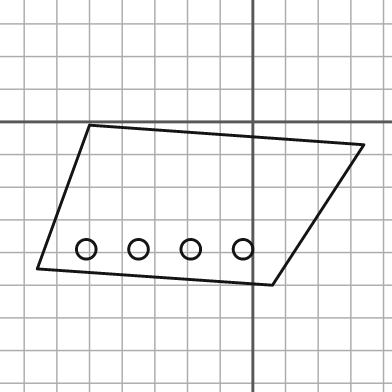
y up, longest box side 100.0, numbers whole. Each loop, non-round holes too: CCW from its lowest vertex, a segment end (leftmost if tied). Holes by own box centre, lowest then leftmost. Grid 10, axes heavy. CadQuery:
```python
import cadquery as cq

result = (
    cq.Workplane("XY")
    .moveTo(6.0, -50.0)
    .lineTo(34.0, -7.0)
    .lineTo(-50.0, -1.0)
    .lineTo(-66.0, -45.0)
    .close()
    .moveTo(-51.0, -39.0)
    .circle(3.0)
    .moveTo(-35.0, -39.0)
    .circle(3.0)
    .moveTo(-19.0, -39.0)
    .circle(3.0)
    .moveTo(-3.0, -39.0)
    .circle(3.0)
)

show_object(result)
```